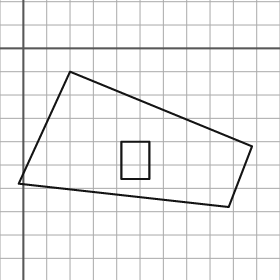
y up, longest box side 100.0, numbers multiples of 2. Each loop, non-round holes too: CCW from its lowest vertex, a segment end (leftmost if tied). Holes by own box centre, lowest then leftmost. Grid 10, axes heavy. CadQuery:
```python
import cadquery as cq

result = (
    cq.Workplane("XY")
    .moveTo(88.0, -68.0)
    .lineTo(98.0, -42.0)
    .lineTo(20.0, -10.0)
    .lineTo(-2.0, -58.0)
    .close()
    .moveTo(42.0, -56.0)
    .lineTo(54.0, -56.0)
    .lineTo(54.0, -40.0)
    .lineTo(42.0, -40.0)
    .close()
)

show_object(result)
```